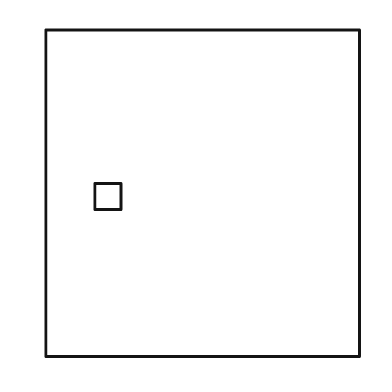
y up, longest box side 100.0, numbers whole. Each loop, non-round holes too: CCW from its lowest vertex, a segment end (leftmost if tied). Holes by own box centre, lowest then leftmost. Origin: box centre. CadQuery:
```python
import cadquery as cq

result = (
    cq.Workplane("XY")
    .moveTo(-48.0, -50.0)
    .lineTo(48.0, -50.0)
    .lineTo(48.0, 50.0)
    .lineTo(-48.0, 50.0)
    .close()
    .moveTo(-33.0, -5.0)
    .lineTo(-25.0, -5.0)
    .lineTo(-25.0, 3.0)
    .lineTo(-33.0, 3.0)
    .close()
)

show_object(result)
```